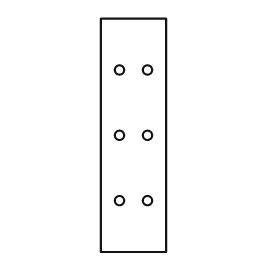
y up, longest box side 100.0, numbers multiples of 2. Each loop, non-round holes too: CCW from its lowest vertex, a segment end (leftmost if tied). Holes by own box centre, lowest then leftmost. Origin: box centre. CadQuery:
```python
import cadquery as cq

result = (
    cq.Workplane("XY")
    .moveTo(-14.0, -50.0)
    .lineTo(14.0, -50.0)
    .lineTo(14.0, 50.0)
    .lineTo(-14.0, 50.0)
    .close()
    .moveTo(-6.0, -28.0)
    .circle(2.0)
    .moveTo(6.0, -28.0)
    .circle(2.0)
    .moveTo(-6.0, 0.0)
    .circle(2.0)
    .moveTo(6.0, 0.0)
    .circle(2.0)
    .moveTo(-6.0, 28.0)
    .circle(2.0)
    .moveTo(6.0, 28.0)
    .circle(2.0)
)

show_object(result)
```